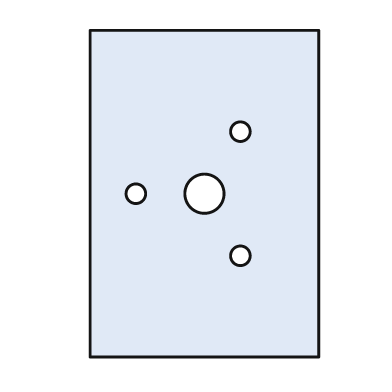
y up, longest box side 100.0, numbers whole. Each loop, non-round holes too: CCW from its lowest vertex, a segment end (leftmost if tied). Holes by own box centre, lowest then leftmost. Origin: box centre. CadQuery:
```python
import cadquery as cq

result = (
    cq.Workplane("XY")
    .moveTo(-35.0, -50.0)
    .lineTo(35.0, -50.0)
    .lineTo(35.0, 50.0)
    .lineTo(-35.0, 50.0)
    .close()
    .moveTo(11.0, -19.0)
    .circle(3.0)
    .moveTo(-21.0, 0.0)
    .circle(3.0)
    .moveTo(0.0, 0.0)
    .circle(6.0)
    .moveTo(11.0, 19.0)
    .circle(3.0)
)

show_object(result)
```